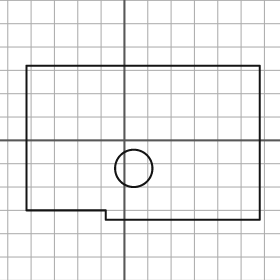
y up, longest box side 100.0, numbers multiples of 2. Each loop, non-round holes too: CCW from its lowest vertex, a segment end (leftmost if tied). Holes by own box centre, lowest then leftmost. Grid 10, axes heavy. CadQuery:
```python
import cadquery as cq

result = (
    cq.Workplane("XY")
    .moveTo(-8.0, -34.0)
    .lineTo(58.0, -34.0)
    .lineTo(58.0, 32.0)
    .lineTo(-42.0, 32.0)
    .lineTo(-42.0, -30.0)
    .lineTo(-8.0, -30.0)
    .close()
    .moveTo(4.0, -12.0)
    .circle(8.0)
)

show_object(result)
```